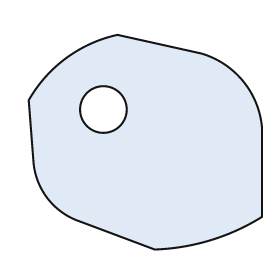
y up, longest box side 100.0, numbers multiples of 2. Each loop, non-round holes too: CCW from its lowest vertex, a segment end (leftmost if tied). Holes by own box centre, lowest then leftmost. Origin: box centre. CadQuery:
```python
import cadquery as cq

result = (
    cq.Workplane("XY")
    .moveTo(4.0, -46.0)
    .threePointArc((28.0, -42.0), (50.0, -32.0))
    .lineTo(50.0, 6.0)
    .threePointArc((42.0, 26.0), (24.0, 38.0))
    .lineTo(-12.0, 46.0)
    .threePointArc((-34.0, 36.0), (-50.0, 18.0))
    .lineTo(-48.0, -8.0)
    .threePointArc((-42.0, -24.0), (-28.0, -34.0))
    .close()
    .moveTo(-18.0, 14.0)
    .circle(10.0)
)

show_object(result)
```